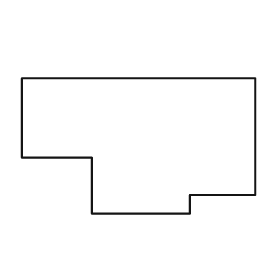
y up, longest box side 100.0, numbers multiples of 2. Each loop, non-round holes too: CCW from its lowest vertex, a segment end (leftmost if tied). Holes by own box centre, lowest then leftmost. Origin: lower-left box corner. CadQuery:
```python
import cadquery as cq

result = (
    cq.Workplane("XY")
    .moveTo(30.0, 0.0)
    .lineTo(72.0, 0.0)
    .lineTo(72.0, 8.0)
    .lineTo(100.0, 8.0)
    .lineTo(100.0, 58.0)
    .lineTo(0.0, 58.0)
    .lineTo(0.0, 24.0)
    .lineTo(30.0, 24.0)
    .close()
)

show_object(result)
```